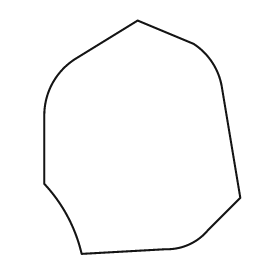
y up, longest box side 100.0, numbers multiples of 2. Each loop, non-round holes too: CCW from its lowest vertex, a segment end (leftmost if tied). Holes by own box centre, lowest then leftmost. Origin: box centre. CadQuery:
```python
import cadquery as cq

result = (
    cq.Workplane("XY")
    .moveTo(-26.0, -50.0)
    .lineTo(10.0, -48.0)
    .threePointArc((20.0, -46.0), (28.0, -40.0))
    .lineTo(42.0, -26.0)
    .lineTo(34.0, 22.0)
    .threePointArc((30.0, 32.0), (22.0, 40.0))
    .lineTo(-2.0, 50.0)
    .lineTo(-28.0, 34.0)
    .threePointArc((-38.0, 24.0), (-42.0, 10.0))
    .lineTo(-42.0, -20.0)
    .threePointArc((-32.0, -34.0), (-26.0, -50.0))
    .close()
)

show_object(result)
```